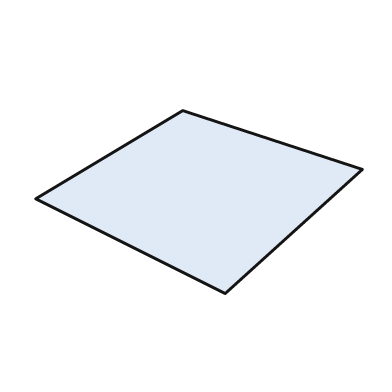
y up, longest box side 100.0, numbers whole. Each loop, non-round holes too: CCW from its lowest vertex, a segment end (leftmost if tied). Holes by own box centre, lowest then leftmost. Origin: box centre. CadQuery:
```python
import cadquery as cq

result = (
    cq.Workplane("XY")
    .moveTo(8.0, -28.0)
    .lineTo(50.0, 10.0)
    .lineTo(-5.0, 28.0)
    .lineTo(-50.0, 1.0)
    .close()
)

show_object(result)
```